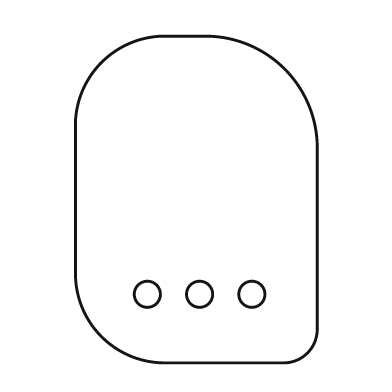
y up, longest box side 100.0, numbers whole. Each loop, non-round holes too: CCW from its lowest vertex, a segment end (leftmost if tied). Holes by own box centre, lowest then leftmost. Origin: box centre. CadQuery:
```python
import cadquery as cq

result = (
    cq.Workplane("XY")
    .moveTo(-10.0, -50.0)
    .lineTo(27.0, -50.0)
    .threePointArc((34.0, -47.0), (37.0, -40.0))
    .lineTo(37.0, 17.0)
    .threePointArc((27.0, 40.0), (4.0, 50.0))
    .lineTo(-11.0, 50.0)
    .threePointArc((-29.0, 42.0), (-37.0, 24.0))
    .lineTo(-37.0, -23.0)
    .threePointArc((-29.0, -42.0), (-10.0, -50.0))
    .close()
    .moveTo(-15.0, -29.0)
    .circle(4.0)
    .moveTo(1.0, -29.0)
    .circle(4.0)
    .moveTo(17.0, -29.0)
    .circle(4.0)
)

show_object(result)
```